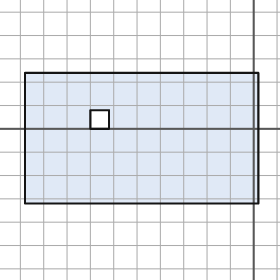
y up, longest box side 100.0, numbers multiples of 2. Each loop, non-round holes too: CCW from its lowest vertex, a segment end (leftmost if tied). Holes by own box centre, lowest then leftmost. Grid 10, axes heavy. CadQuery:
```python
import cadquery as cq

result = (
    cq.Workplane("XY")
    .moveTo(-98.0, -32.0)
    .lineTo(2.0, -32.0)
    .lineTo(2.0, 24.0)
    .lineTo(-98.0, 24.0)
    .close()
    .moveTo(-70.0, 0.0)
    .lineTo(-62.0, 0.0)
    .lineTo(-62.0, 8.0)
    .lineTo(-70.0, 8.0)
    .close()
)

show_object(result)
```